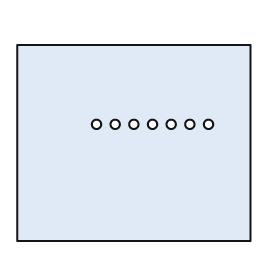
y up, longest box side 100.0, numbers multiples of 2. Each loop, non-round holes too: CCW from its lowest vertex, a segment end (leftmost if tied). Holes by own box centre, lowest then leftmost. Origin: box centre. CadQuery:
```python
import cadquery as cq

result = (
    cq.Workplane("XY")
    .moveTo(-50.0, -42.0)
    .lineTo(50.0, -42.0)
    .lineTo(50.0, 42.0)
    .lineTo(-50.0, 42.0)
    .close()
    .moveTo(-16.0, 8.0)
    .circle(2.0)
    .moveTo(-8.0, 8.0)
    .circle(2.0)
    .moveTo(0.0, 8.0)
    .circle(2.0)
    .moveTo(8.0, 8.0)
    .circle(2.0)
    .moveTo(16.0, 8.0)
    .circle(2.0)
    .moveTo(24.0, 8.0)
    .circle(2.0)
    .moveTo(32.0, 8.0)
    .circle(2.0)
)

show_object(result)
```